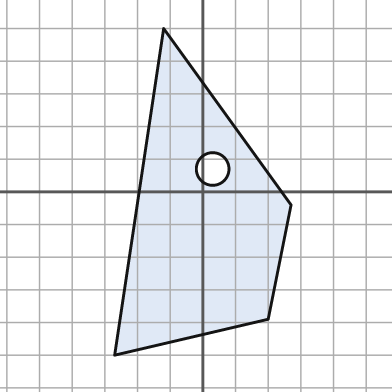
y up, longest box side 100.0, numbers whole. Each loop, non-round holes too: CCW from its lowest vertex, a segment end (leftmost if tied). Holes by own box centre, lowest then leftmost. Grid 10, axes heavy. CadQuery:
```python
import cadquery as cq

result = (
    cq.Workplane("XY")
    .moveTo(-27.0, -50.0)
    .lineTo(20.0, -39.0)
    .lineTo(27.0, -4.0)
    .lineTo(-12.0, 50.0)
    .close()
    .moveTo(3.0, 7.0)
    .circle(5.0)
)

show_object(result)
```